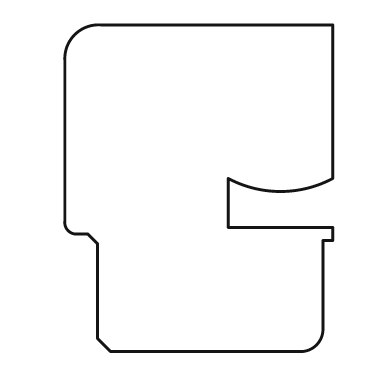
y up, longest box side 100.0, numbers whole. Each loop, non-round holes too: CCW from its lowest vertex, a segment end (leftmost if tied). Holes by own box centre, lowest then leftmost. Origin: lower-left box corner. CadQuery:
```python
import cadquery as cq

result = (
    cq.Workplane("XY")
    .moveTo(14.0, 0.0)
    .lineTo(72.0, 0.0)
    .threePointArc((77.0, 2.0), (79.0, 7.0))
    .lineTo(79.0, 34.0)
    .lineTo(82.0, 34.0)
    .lineTo(82.0, 38.0)
    .lineTo(50.0, 38.0)
    .lineTo(50.0, 53.0)
    .threePointArc((66.0, 49.0), (82.0, 53.0))
    .lineTo(82.0, 100.0)
    .lineTo(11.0, 100.0)
    .threePointArc((3.0, 97.0), (0.0, 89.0))
    .lineTo(0.0, 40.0)
    .threePointArc((1.0, 37.0), (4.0, 36.0))
    .lineTo(7.0, 36.0)
    .lineTo(10.0, 33.0)
    .lineTo(10.0, 4.0)
    .close()
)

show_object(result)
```